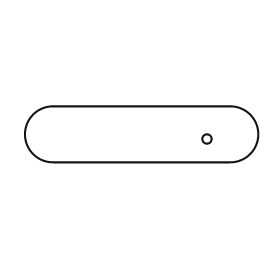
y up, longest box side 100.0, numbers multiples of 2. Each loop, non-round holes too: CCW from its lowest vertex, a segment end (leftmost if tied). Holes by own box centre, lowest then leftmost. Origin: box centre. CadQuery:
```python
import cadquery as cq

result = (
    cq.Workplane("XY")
    .moveTo(-38.0, -12.0)
    .lineTo(38.0, -12.0)
    .threePointArc((50.0, 0.0), (38.0, 12.0))
    .lineTo(-38.0, 12.0)
    .threePointArc((-50.0, 0.0), (-38.0, -12.0))
    .close()
    .moveTo(28.0, -2.0)
    .circle(2.0)
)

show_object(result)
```